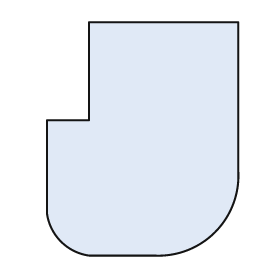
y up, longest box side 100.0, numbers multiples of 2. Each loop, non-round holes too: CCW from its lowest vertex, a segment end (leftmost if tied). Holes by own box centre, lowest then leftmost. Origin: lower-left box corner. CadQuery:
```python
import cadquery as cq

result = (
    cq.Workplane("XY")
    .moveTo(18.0, 0.0)
    .lineTo(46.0, 0.0)
    .threePointArc((72.0, 10.0), (82.0, 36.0))
    .lineTo(82.0, 100.0)
    .lineTo(18.0, 100.0)
    .lineTo(18.0, 58.0)
    .lineTo(0.0, 58.0)
    .lineTo(0.0, 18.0)
    .threePointArc((6.0, 6.0), (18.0, 0.0))
    .close()
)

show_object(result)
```